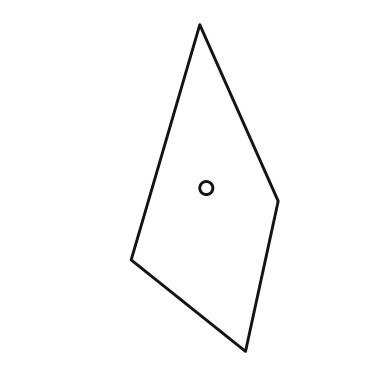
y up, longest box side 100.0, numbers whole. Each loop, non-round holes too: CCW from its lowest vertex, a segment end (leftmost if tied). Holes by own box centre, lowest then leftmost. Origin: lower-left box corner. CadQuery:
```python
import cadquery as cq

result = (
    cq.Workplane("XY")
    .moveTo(35.0, 0.0)
    .lineTo(45.0, 46.0)
    .lineTo(21.0, 100.0)
    .lineTo(0.0, 28.0)
    .close()
    .moveTo(23.0, 50.0)
    .circle(2.0)
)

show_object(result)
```